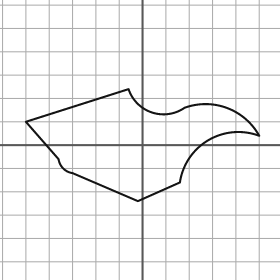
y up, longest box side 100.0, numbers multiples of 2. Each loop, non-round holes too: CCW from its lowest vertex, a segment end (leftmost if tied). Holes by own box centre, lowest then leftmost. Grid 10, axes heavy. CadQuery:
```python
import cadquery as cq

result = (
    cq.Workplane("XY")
    .moveTo(-2.0, -24.0)
    .lineTo(16.0, -16.0)
    .threePointArc((28.0, 2.0), (50.0, 4.0))
    .threePointArc((36.0, 16.0), (18.0, 16.0))
    .threePointArc((4.0, 14.0), (-6.0, 24.0))
    .lineTo(-50.0, 10.0)
    .lineTo(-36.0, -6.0)
    .threePointArc((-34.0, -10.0), (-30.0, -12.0))
    .close()
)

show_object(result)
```